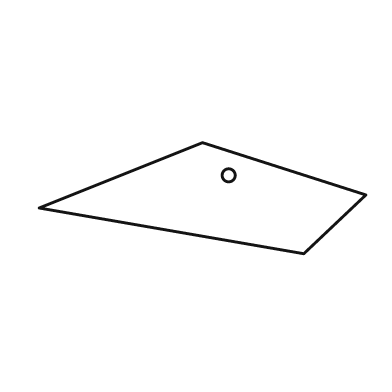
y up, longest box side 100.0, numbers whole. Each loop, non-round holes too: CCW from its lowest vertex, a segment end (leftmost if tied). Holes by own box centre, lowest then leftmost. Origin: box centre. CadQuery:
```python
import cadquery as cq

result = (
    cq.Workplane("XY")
    .moveTo(31.0, -17.0)
    .lineTo(50.0, 1.0)
    .lineTo(0.0, 17.0)
    .lineTo(-50.0, -3.0)
    .close()
    .moveTo(8.0, 7.0)
    .circle(2.0)
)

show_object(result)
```